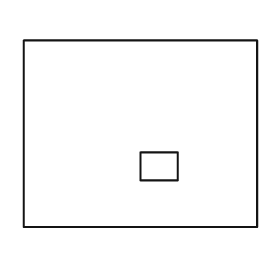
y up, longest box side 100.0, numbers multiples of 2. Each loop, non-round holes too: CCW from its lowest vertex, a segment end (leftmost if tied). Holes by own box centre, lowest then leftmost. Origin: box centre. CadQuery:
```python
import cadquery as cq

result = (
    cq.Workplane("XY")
    .moveTo(-50.0, -40.0)
    .lineTo(50.0, -40.0)
    .lineTo(50.0, 40.0)
    .lineTo(-50.0, 40.0)
    .close()
    .moveTo(0.0, -20.0)
    .lineTo(16.0, -20.0)
    .lineTo(16.0, -8.0)
    .lineTo(0.0, -8.0)
    .close()
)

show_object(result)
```